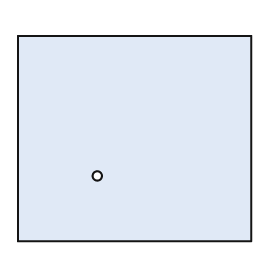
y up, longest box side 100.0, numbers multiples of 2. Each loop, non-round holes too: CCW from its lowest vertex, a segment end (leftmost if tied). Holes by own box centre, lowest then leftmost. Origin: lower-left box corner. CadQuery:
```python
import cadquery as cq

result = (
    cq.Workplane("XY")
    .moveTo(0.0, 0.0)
    .lineTo(100.0, 0.0)
    .lineTo(100.0, 88.0)
    .lineTo(0.0, 88.0)
    .close()
    .moveTo(34.0, 28.0)
    .circle(2.0)
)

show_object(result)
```